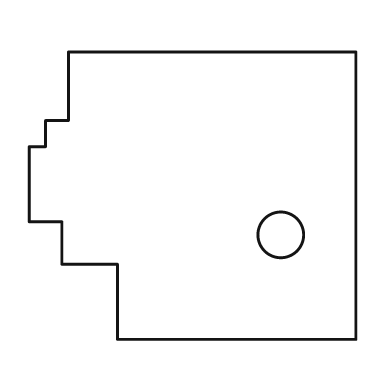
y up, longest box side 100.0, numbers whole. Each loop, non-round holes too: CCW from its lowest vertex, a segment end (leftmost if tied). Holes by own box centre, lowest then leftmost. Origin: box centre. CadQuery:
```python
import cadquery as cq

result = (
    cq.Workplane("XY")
    .moveTo(-23.0, -44.0)
    .lineTo(50.0, -44.0)
    .lineTo(50.0, 44.0)
    .lineTo(-38.0, 44.0)
    .lineTo(-38.0, 23.0)
    .lineTo(-45.0, 23.0)
    .lineTo(-45.0, 15.0)
    .lineTo(-50.0, 15.0)
    .lineTo(-50.0, -8.0)
    .lineTo(-40.0, -8.0)
    .lineTo(-40.0, -21.0)
    .lineTo(-23.0, -21.0)
    .close()
    .moveTo(27.0, -12.0)
    .circle(7.0)
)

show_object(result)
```